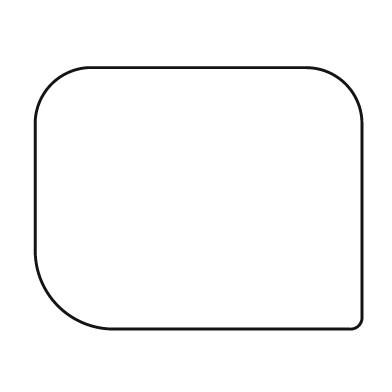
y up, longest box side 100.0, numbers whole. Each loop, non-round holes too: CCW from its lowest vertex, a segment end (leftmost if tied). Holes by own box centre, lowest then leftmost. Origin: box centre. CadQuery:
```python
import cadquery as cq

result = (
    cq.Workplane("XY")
    .moveTo(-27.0, -40.0)
    .lineTo(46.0, -40.0)
    .threePointArc((49.0, -39.0), (50.0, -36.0))
    .lineTo(50.0, 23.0)
    .threePointArc((45.0, 35.0), (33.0, 40.0))
    .lineTo(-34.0, 40.0)
    .threePointArc((-45.0, 35.0), (-50.0, 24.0))
    .lineTo(-50.0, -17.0)
    .threePointArc((-43.0, -33.0), (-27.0, -40.0))
    .close()
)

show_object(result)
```